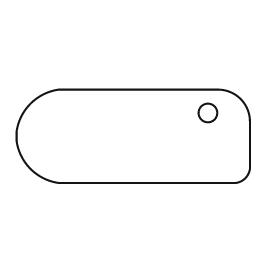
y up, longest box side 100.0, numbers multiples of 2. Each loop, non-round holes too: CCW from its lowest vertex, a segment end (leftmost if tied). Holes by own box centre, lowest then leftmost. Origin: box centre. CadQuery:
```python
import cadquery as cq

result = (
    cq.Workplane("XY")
    .moveTo(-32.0, -20.0)
    .lineTo(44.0, -20.0)
    .threePointArc((48.0, -18.0), (50.0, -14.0))
    .lineTo(50.0, 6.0)
    .threePointArc((46.0, 16.0), (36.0, 20.0))
    .lineTo(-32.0, 20.0)
    .threePointArc((-44.0, 14.0), (-50.0, 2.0))
    .lineTo(-50.0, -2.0)
    .threePointArc((-44.0, -14.0), (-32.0, -20.0))
    .close()
    .moveTo(32.0, 10.0)
    .circle(4.0)
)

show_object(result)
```